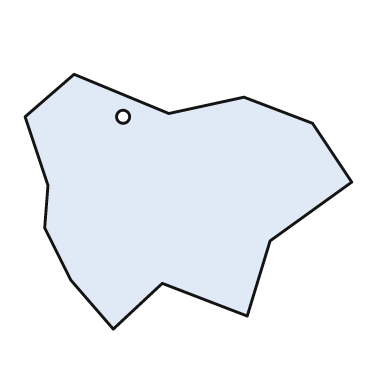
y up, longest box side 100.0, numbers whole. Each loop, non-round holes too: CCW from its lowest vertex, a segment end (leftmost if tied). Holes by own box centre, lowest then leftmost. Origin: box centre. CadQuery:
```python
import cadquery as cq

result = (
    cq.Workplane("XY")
    .moveTo(-23.0, -39.0)
    .lineTo(-8.0, -25.0)
    .lineTo(18.0, -35.0)
    .lineTo(25.0, -12.0)
    .lineTo(50.0, 6.0)
    .lineTo(38.0, 24.0)
    .lineTo(17.0, 32.0)
    .lineTo(-6.0, 27.0)
    .lineTo(-35.0, 39.0)
    .lineTo(-50.0, 26.0)
    .lineTo(-43.0, 5.0)
    .lineTo(-44.0, -8.0)
    .lineTo(-36.0, -24.0)
    .close()
    .moveTo(-20.0, 26.0)
    .circle(2.0)
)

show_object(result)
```